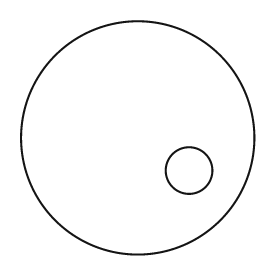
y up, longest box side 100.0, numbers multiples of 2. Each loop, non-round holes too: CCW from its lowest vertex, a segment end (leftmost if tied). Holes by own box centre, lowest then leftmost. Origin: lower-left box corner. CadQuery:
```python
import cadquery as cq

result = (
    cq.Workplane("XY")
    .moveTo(50.0, 50.0)
    .circle(50.0)
    .moveTo(72.0, 36.0)
    .circle(10.0)
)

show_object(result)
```